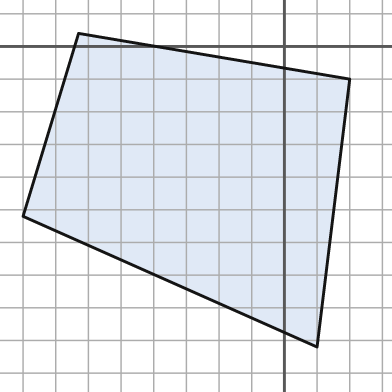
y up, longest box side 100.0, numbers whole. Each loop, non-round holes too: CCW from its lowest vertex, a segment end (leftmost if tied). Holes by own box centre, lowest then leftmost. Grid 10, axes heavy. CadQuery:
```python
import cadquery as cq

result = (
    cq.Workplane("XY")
    .moveTo(10.0, -92.0)
    .lineTo(20.0, -10.0)
    .lineTo(-63.0, 4.0)
    .lineTo(-80.0, -52.0)
    .close()
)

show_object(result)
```